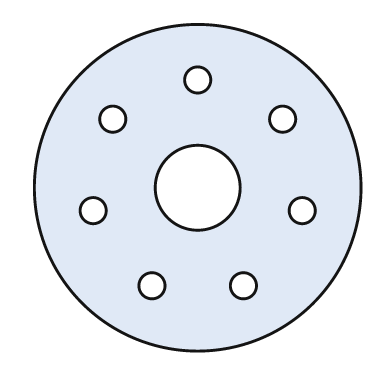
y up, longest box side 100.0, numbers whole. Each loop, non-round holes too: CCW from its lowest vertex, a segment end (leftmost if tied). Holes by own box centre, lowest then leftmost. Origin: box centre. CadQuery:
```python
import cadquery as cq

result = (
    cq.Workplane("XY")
    .moveTo(0.0, 0.0)
    .circle(50.0)
    .moveTo(-14.0, -30.0)
    .circle(4.0)
    .moveTo(14.0, -30.0)
    .circle(4.0)
    .moveTo(-32.0, -7.0)
    .circle(4.0)
    .moveTo(32.0, -7.0)
    .circle(4.0)
    .moveTo(0.0, 0.0)
    .circle(13.0)
    .moveTo(-26.0, 21.0)
    .circle(4.0)
    .moveTo(26.0, 21.0)
    .circle(4.0)
    .moveTo(0.0, 33.0)
    .circle(4.0)
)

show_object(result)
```